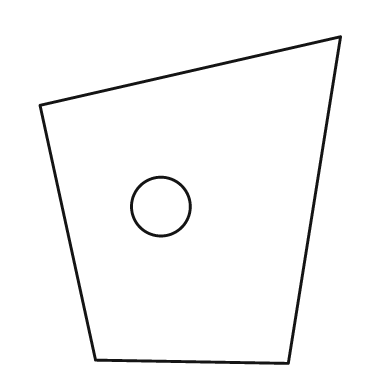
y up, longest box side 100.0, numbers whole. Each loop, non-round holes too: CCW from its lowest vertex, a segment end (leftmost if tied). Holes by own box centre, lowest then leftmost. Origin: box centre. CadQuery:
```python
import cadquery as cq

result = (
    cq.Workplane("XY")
    .moveTo(30.0, -50.0)
    .lineTo(46.0, 50.0)
    .lineTo(-46.0, 29.0)
    .lineTo(-29.0, -49.0)
    .close()
    .moveTo(-9.0, -2.0)
    .circle(9.0)
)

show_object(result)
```